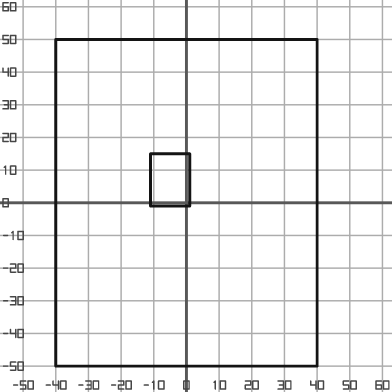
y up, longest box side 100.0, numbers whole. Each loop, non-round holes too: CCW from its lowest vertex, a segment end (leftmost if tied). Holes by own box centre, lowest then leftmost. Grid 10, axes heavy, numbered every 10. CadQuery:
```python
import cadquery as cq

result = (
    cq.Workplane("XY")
    .moveTo(-40.0, -50.0)
    .lineTo(40.0, -50.0)
    .lineTo(40.0, 50.0)
    .lineTo(-40.0, 50.0)
    .close()
    .moveTo(-11.0, -1.0)
    .lineTo(1.0, -1.0)
    .lineTo(1.0, 15.0)
    .lineTo(-11.0, 15.0)
    .close()
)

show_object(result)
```